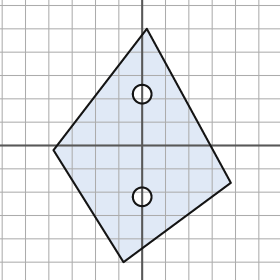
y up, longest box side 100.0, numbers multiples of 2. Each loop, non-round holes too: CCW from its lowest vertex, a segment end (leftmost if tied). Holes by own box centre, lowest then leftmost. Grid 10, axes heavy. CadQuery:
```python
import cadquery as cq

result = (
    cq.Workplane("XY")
    .moveTo(-8.0, -50.0)
    .lineTo(38.0, -16.0)
    .lineTo(2.0, 50.0)
    .lineTo(-38.0, -2.0)
    .close()
    .moveTo(0.0, -22.0)
    .circle(4.0)
    .moveTo(0.0, 22.0)
    .circle(4.0)
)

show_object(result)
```